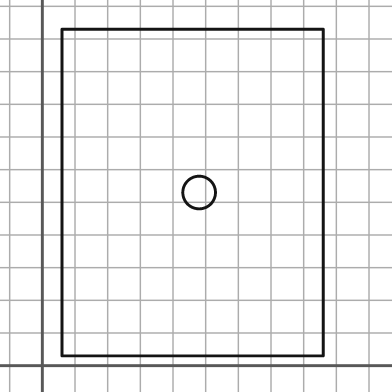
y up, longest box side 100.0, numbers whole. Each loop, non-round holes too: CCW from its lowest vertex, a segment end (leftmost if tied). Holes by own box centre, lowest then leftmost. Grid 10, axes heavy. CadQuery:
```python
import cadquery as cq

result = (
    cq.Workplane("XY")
    .moveTo(6.0, 3.0)
    .lineTo(86.0, 3.0)
    .lineTo(86.0, 103.0)
    .lineTo(6.0, 103.0)
    .close()
    .moveTo(48.0, 53.0)
    .circle(5.0)
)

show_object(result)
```